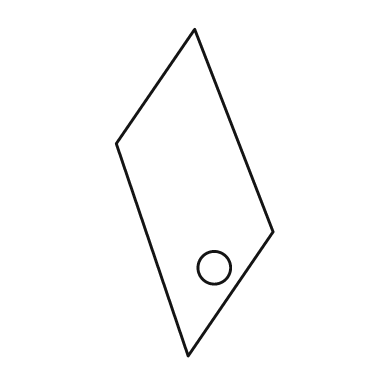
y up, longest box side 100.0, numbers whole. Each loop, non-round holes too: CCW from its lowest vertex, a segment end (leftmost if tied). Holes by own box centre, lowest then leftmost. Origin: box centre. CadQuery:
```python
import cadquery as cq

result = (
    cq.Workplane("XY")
    .moveTo(-2.0, -50.0)
    .lineTo(24.0, -12.0)
    .lineTo(0.0, 50.0)
    .lineTo(-24.0, 15.0)
    .close()
    .moveTo(6.0, -23.0)
    .circle(5.0)
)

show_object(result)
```